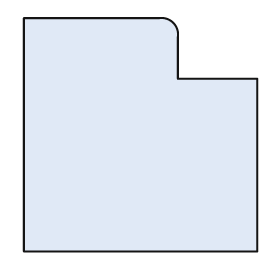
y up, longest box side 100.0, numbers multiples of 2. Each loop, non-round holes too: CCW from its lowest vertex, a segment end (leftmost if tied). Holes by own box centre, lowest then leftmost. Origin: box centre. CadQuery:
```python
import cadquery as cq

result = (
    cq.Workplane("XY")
    .moveTo(-50.0, -50.0)
    .lineTo(50.0, -50.0)
    .lineTo(50.0, 24.0)
    .lineTo(16.0, 24.0)
    .lineTo(16.0, 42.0)
    .threePointArc((14.0, 48.0), (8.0, 50.0))
    .lineTo(-50.0, 50.0)
    .close()
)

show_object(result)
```